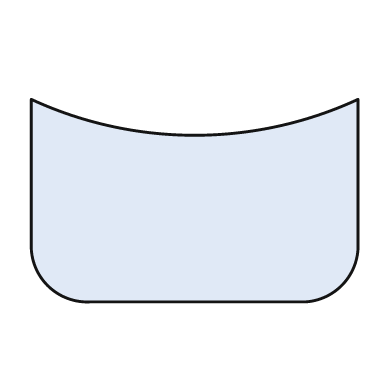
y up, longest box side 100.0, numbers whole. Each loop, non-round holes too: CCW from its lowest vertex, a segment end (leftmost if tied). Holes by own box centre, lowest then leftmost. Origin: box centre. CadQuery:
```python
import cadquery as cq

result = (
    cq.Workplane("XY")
    .moveTo(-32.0, -31.0)
    .lineTo(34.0, -31.0)
    .threePointArc((45.0, -26.0), (50.0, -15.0))
    .lineTo(50.0, 31.0)
    .threePointArc((0.0, 20.0), (-50.0, 31.0))
    .lineTo(-50.0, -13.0)
    .threePointArc((-45.0, -26.0), (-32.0, -31.0))
    .close()
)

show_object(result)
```